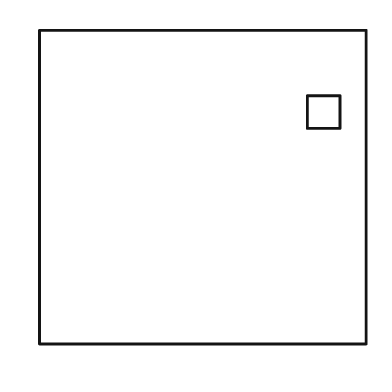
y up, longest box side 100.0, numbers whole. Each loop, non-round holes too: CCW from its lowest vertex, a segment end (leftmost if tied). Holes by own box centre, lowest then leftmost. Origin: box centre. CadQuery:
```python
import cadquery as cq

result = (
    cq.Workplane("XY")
    .moveTo(-50.0, -48.0)
    .lineTo(50.0, -48.0)
    .lineTo(50.0, 48.0)
    .lineTo(-50.0, 48.0)
    .close()
    .moveTo(32.0, 18.0)
    .lineTo(42.0, 18.0)
    .lineTo(42.0, 28.0)
    .lineTo(32.0, 28.0)
    .close()
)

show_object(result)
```